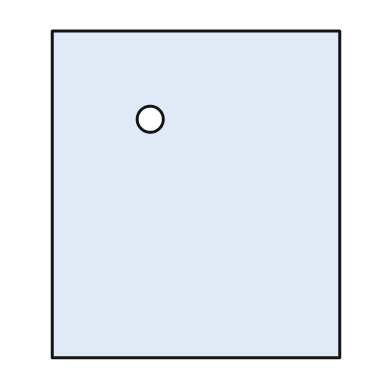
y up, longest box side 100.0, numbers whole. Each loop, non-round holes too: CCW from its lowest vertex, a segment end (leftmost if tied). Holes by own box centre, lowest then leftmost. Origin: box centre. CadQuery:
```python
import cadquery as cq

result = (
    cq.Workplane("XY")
    .moveTo(-44.0, -50.0)
    .lineTo(44.0, -50.0)
    .lineTo(44.0, 50.0)
    .lineTo(-44.0, 50.0)
    .close()
    .moveTo(-14.0, 23.0)
    .circle(4.0)
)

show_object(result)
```